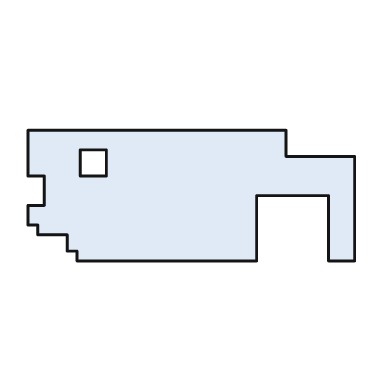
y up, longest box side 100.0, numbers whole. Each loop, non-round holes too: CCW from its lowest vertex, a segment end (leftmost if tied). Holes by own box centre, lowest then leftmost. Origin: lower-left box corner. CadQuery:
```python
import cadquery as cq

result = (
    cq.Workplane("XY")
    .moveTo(15.0, 0.0)
    .lineTo(70.0, 0.0)
    .lineTo(70.0, 20.0)
    .lineTo(92.0, 20.0)
    .lineTo(92.0, 0.0)
    .lineTo(100.0, 0.0)
    .lineTo(100.0, 32.0)
    .lineTo(79.0, 32.0)
    .lineTo(79.0, 40.0)
    .lineTo(0.0, 40.0)
    .lineTo(0.0, 26.0)
    .lineTo(5.0, 26.0)
    .lineTo(5.0, 17.0)
    .lineTo(0.0, 17.0)
    .lineTo(0.0, 11.0)
    .lineTo(3.0, 11.0)
    .lineTo(3.0, 8.0)
    .lineTo(12.0, 8.0)
    .lineTo(12.0, 3.0)
    .lineTo(15.0, 3.0)
    .close()
    .moveTo(16.0, 26.0)
    .lineTo(24.0, 26.0)
    .lineTo(24.0, 34.0)
    .lineTo(16.0, 34.0)
    .close()
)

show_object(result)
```